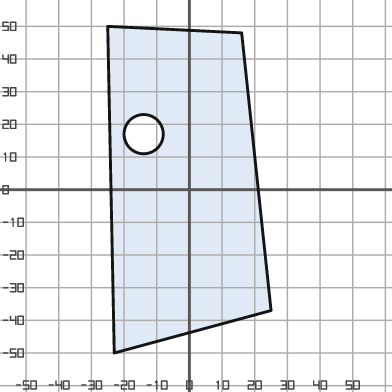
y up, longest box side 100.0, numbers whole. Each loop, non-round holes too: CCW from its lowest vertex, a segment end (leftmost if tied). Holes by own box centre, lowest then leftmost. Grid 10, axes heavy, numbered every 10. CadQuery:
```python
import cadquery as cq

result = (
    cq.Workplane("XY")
    .moveTo(-23.0, -50.0)
    .lineTo(25.0, -37.0)
    .lineTo(16.0, 48.0)
    .lineTo(-25.0, 50.0)
    .close()
    .moveTo(-14.0, 17.0)
    .circle(6.0)
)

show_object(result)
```